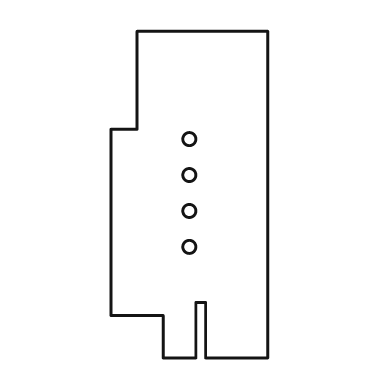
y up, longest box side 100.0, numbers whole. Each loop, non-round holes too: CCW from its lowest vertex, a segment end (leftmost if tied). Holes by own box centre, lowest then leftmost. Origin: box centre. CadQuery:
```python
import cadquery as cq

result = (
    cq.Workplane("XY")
    .moveTo(-8.0, -50.0)
    .lineTo(2.0, -50.0)
    .lineTo(2.0, -33.0)
    .lineTo(5.0, -33.0)
    .lineTo(5.0, -50.0)
    .lineTo(24.0, -50.0)
    .lineTo(24.0, 50.0)
    .lineTo(-16.0, 50.0)
    .lineTo(-16.0, 20.0)
    .lineTo(-24.0, 20.0)
    .lineTo(-24.0, -37.0)
    .lineTo(-8.0, -37.0)
    .close()
    .moveTo(0.0, -16.0)
    .circle(2.0)
    .moveTo(0.0, -5.0)
    .circle(2.0)
    .moveTo(0.0, 6.0)
    .circle(2.0)
    .moveTo(0.0, 17.0)
    .circle(2.0)
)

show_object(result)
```